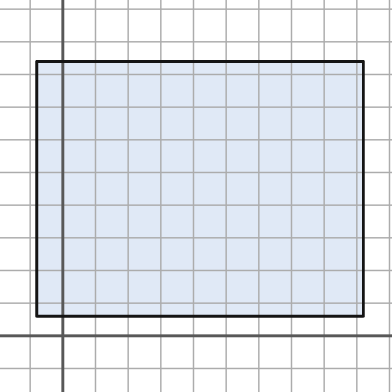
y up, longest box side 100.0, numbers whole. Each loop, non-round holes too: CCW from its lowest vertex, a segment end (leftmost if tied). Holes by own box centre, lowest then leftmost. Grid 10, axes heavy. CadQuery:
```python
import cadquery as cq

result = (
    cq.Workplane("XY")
    .moveTo(-8.0, 6.0)
    .lineTo(92.0, 6.0)
    .lineTo(92.0, 84.0)
    .lineTo(-8.0, 84.0)
    .close()
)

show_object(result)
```